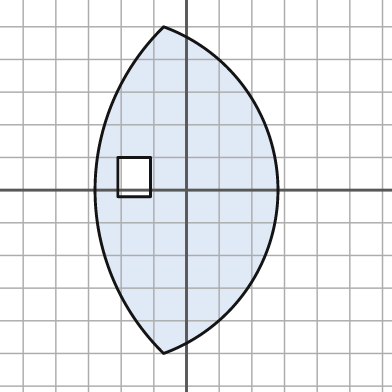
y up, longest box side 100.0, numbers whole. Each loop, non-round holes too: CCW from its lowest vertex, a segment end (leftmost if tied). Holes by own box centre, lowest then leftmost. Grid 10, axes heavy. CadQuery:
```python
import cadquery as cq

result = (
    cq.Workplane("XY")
    .moveTo(-7.0, -50.0)
    .threePointArc((28.0, 0.0), (-7.0, 50.0))
    .threePointArc((-28.0, 0.0), (-7.0, -50.0))
    .close()
    .moveTo(-21.0, -2.0)
    .lineTo(-11.0, -2.0)
    .lineTo(-11.0, 10.0)
    .lineTo(-21.0, 10.0)
    .close()
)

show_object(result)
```